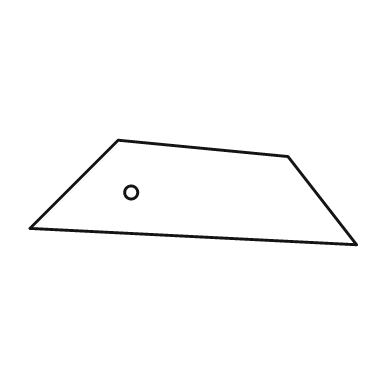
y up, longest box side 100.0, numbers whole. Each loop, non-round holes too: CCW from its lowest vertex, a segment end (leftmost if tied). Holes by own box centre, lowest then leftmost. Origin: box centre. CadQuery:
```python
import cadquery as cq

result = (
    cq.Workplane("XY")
    .moveTo(50.0, -16.0)
    .lineTo(29.0, 11.0)
    .lineTo(-23.0, 16.0)
    .lineTo(-50.0, -11.0)
    .close()
    .moveTo(-19.0, 0.0)
    .circle(2.0)
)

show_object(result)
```